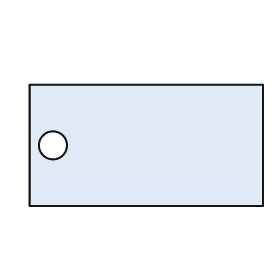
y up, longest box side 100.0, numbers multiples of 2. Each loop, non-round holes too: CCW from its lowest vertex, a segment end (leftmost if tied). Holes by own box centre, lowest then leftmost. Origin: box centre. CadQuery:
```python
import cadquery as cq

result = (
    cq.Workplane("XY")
    .moveTo(-50.0, -26.0)
    .lineTo(50.0, -26.0)
    .lineTo(50.0, 26.0)
    .lineTo(-50.0, 26.0)
    .close()
    .moveTo(-40.0, 0.0)
    .circle(6.0)
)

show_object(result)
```